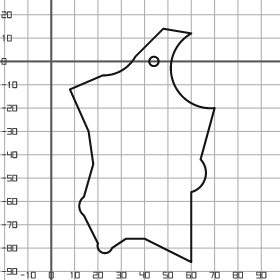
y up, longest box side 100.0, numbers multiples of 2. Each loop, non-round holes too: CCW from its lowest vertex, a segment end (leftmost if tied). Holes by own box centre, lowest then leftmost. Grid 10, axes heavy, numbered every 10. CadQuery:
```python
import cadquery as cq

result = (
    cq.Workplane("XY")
    .moveTo(60.0, -86.0)
    .lineTo(60.0, -56.0)
    .threePointArc((66.0, -50.0), (64.0, -42.0))
    .lineTo(70.0, -20.0)
    .threePointArc((52.0, -8.0), (60.0, 12.0))
    .lineTo(48.0, 14.0)
    .lineTo(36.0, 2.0)
    .threePointArc((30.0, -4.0), (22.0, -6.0))
    .lineTo(8.0, -12.0)
    .lineTo(16.0, -30.0)
    .lineTo(18.0, -44.0)
    .lineTo(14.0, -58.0)
    .threePointArc((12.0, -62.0), (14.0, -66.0))
    .lineTo(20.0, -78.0)
    .threePointArc((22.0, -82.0), (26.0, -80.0))
    .lineTo(32.0, -76.0)
    .lineTo(40.0, -76.0)
    .close()
    .moveTo(44.0, 0.0)
    .circle(2.0)
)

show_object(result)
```